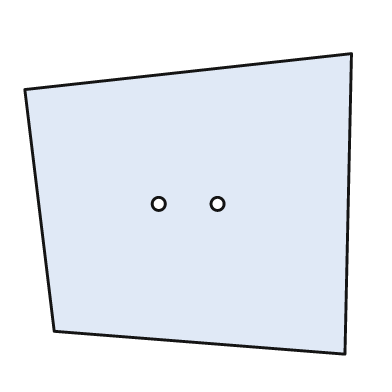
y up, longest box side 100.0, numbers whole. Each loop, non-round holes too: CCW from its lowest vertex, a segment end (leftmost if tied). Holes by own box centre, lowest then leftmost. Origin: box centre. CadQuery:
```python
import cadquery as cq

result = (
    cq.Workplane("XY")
    .moveTo(48.0, -46.0)
    .lineTo(50.0, 46.0)
    .lineTo(-50.0, 35.0)
    .lineTo(-41.0, -39.0)
    .close()
    .moveTo(-9.0, 0.0)
    .circle(2.0)
    .moveTo(9.0, 0.0)
    .circle(2.0)
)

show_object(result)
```